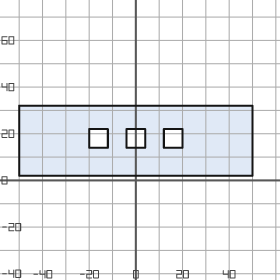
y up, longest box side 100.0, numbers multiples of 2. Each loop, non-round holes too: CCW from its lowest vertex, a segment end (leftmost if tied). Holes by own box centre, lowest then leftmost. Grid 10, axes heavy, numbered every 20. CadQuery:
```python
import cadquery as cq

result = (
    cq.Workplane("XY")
    .moveTo(-50.0, 2.0)
    .lineTo(50.0, 2.0)
    .lineTo(50.0, 32.0)
    .lineTo(-50.0, 32.0)
    .close()
    .moveTo(-20.0, 14.0)
    .lineTo(-12.0, 14.0)
    .lineTo(-12.0, 22.0)
    .lineTo(-20.0, 22.0)
    .close()
    .moveTo(-4.0, 14.0)
    .lineTo(4.0, 14.0)
    .lineTo(4.0, 22.0)
    .lineTo(-4.0, 22.0)
    .close()
    .moveTo(12.0, 14.0)
    .lineTo(20.0, 14.0)
    .lineTo(20.0, 22.0)
    .lineTo(12.0, 22.0)
    .close()
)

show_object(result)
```